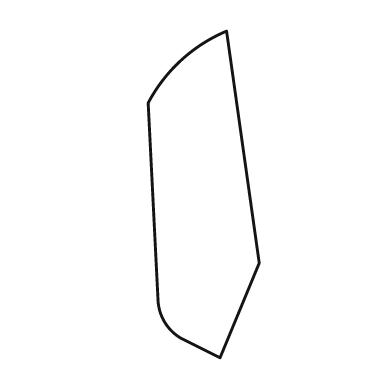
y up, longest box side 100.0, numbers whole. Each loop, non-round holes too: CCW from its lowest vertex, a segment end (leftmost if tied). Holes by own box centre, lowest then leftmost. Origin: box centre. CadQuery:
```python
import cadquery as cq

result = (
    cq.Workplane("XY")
    .moveTo(5.0, -50.0)
    .lineTo(17.0, -21.0)
    .lineTo(7.0, 50.0)
    .threePointArc((-7.0, 41.0), (-17.0, 28.0))
    .lineTo(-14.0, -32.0)
    .threePointArc((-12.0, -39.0), (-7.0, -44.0))
    .close()
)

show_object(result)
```